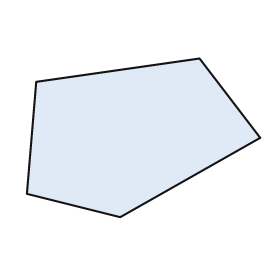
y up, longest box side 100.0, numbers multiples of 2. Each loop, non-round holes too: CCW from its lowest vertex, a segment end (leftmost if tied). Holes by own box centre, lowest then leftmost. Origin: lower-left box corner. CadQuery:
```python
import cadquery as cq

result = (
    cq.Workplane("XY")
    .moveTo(40.0, 0.0)
    .lineTo(100.0, 34.0)
    .lineTo(74.0, 68.0)
    .lineTo(4.0, 58.0)
    .lineTo(0.0, 10.0)
    .close()
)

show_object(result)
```